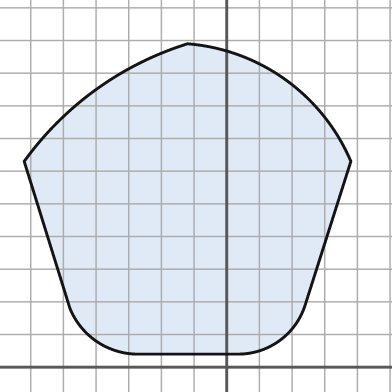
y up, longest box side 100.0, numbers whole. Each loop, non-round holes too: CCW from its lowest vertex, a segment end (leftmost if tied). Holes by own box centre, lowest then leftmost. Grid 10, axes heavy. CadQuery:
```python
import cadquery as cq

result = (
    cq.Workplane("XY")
    .moveTo(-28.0, 4.0)
    .lineTo(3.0, 4.0)
    .threePointArc((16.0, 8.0), (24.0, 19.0))
    .lineTo(38.0, 63.0)
    .threePointArc((18.0, 88.0), (-12.0, 99.0))
    .threePointArc((-40.0, 85.0), (-62.0, 63.0))
    .lineTo(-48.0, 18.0)
    .threePointArc((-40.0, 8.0), (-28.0, 4.0))
    .close()
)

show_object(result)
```